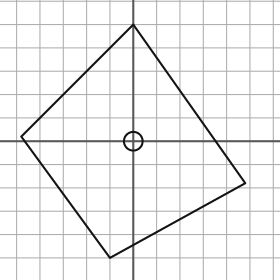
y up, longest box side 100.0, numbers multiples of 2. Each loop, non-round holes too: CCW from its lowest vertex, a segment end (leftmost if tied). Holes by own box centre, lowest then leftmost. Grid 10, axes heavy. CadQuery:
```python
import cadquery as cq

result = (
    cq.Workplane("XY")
    .moveTo(-10.0, -50.0)
    .lineTo(48.0, -18.0)
    .lineTo(0.0, 50.0)
    .lineTo(-48.0, 2.0)
    .close()
    .moveTo(0.0, 0.0)
    .circle(4.0)
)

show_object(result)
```